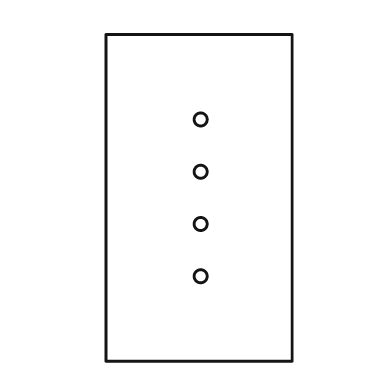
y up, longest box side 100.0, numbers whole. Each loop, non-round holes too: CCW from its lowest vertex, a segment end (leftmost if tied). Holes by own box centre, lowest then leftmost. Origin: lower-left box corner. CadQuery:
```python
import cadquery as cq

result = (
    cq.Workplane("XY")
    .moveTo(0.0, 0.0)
    .lineTo(57.0, 0.0)
    .lineTo(57.0, 100.0)
    .lineTo(0.0, 100.0)
    .close()
    .moveTo(29.0, 26.0)
    .circle(2.0)
    .moveTo(29.0, 42.0)
    .circle(2.0)
    .moveTo(29.0, 58.0)
    .circle(2.0)
    .moveTo(29.0, 74.0)
    .circle(2.0)
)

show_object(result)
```